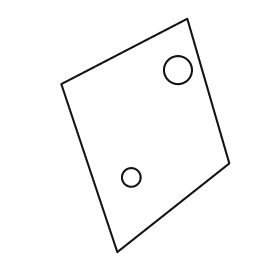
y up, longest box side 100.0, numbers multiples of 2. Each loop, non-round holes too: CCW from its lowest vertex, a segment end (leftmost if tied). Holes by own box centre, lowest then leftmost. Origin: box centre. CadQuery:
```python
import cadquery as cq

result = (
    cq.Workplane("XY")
    .moveTo(-12.0, -50.0)
    .lineTo(36.0, -12.0)
    .lineTo(18.0, 50.0)
    .lineTo(-36.0, 22.0)
    .close()
    .moveTo(-6.0, -18.0)
    .circle(4.0)
    .moveTo(14.0, 28.0)
    .circle(6.0)
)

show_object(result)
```